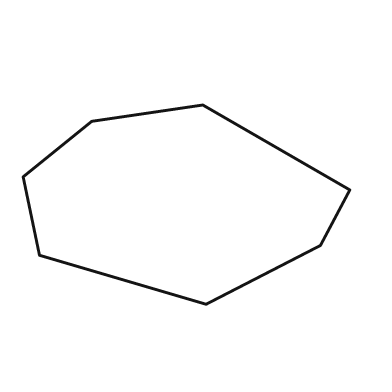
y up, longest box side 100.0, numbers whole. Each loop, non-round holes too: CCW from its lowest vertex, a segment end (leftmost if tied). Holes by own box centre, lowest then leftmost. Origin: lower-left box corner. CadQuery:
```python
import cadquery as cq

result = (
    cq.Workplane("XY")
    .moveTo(56.0, 0.0)
    .lineTo(91.0, 18.0)
    .lineTo(100.0, 35.0)
    .lineTo(55.0, 61.0)
    .lineTo(21.0, 56.0)
    .lineTo(0.0, 39.0)
    .lineTo(5.0, 15.0)
    .close()
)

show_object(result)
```